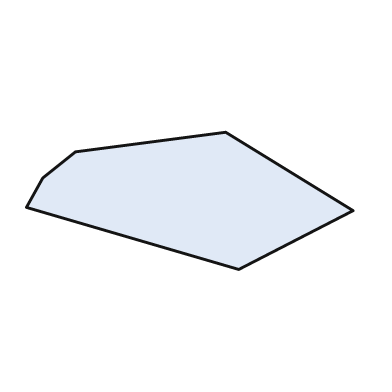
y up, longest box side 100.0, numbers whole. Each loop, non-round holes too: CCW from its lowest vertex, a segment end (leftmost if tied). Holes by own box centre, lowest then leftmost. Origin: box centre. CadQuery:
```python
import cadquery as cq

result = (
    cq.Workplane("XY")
    .moveTo(15.0, -21.0)
    .lineTo(50.0, -3.0)
    .lineTo(11.0, 21.0)
    .lineTo(-35.0, 15.0)
    .lineTo(-45.0, 7.0)
    .lineTo(-50.0, -2.0)
    .close()
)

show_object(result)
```